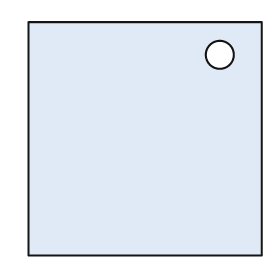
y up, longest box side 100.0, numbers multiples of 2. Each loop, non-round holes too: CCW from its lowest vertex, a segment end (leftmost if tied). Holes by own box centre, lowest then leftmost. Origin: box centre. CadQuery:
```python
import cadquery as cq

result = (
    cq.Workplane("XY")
    .moveTo(-50.0, -50.0)
    .lineTo(50.0, -50.0)
    .lineTo(50.0, 50.0)
    .lineTo(-50.0, 50.0)
    .close()
    .moveTo(32.0, 36.0)
    .circle(6.0)
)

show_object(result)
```